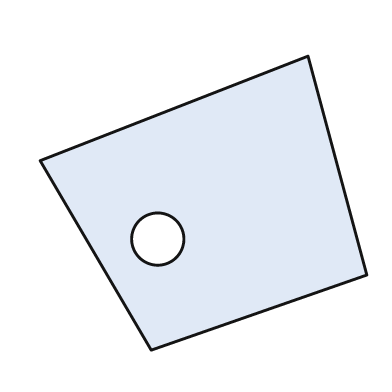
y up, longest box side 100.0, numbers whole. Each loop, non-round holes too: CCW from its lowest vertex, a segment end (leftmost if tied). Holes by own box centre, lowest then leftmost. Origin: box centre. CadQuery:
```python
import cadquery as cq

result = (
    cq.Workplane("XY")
    .moveTo(-16.0, -45.0)
    .lineTo(50.0, -22.0)
    .lineTo(32.0, 45.0)
    .lineTo(-50.0, 13.0)
    .close()
    .moveTo(-14.0, -11.0)
    .circle(8.0)
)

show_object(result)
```